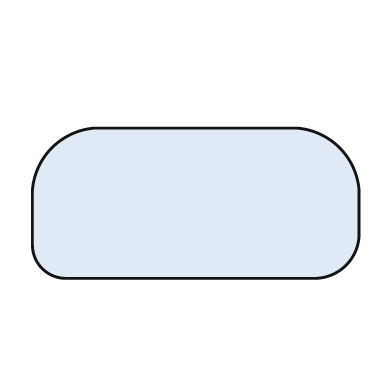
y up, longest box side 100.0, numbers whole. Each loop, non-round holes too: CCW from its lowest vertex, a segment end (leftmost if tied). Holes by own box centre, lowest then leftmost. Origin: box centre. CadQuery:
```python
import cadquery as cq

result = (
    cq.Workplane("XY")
    .moveTo(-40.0, -23.0)
    .lineTo(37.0, -23.0)
    .threePointArc((46.0, -19.0), (50.0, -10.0))
    .lineTo(50.0, 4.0)
    .threePointArc((44.0, 17.0), (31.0, 23.0))
    .lineTo(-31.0, 23.0)
    .threePointArc((-44.0, 17.0), (-50.0, 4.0))
    .lineTo(-50.0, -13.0)
    .threePointArc((-47.0, -20.0), (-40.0, -23.0))
    .close()
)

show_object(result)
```